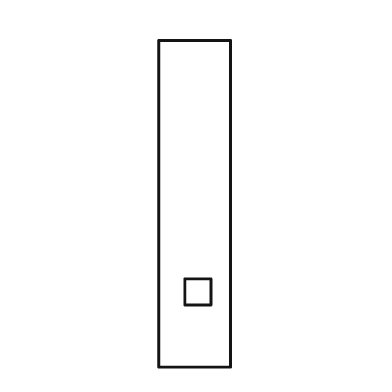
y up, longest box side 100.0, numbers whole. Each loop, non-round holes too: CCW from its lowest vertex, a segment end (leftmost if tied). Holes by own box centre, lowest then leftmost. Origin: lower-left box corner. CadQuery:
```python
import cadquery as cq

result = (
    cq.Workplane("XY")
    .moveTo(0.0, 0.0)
    .lineTo(22.0, 0.0)
    .lineTo(22.0, 100.0)
    .lineTo(0.0, 100.0)
    .close()
    .moveTo(8.0, 19.0)
    .lineTo(16.0, 19.0)
    .lineTo(16.0, 27.0)
    .lineTo(8.0, 27.0)
    .close()
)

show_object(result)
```